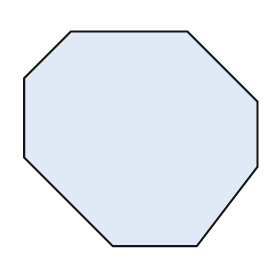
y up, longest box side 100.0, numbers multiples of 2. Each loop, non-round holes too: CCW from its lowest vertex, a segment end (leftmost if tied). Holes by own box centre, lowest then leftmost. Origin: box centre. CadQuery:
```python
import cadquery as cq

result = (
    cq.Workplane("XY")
    .moveTo(-12.0, -46.0)
    .lineTo(24.0, -46.0)
    .lineTo(50.0, -12.0)
    .lineTo(50.0, 16.0)
    .lineTo(20.0, 46.0)
    .lineTo(-30.0, 46.0)
    .lineTo(-50.0, 26.0)
    .lineTo(-50.0, -8.0)
    .close()
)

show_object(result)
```